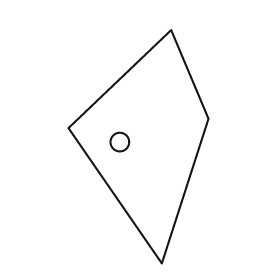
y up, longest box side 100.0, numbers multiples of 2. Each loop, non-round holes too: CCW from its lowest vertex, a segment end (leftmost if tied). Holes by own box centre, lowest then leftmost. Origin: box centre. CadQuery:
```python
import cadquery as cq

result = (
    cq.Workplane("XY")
    .moveTo(10.0, -50.0)
    .lineTo(30.0, 12.0)
    .lineTo(14.0, 50.0)
    .lineTo(-30.0, 8.0)
    .close()
    .moveTo(-8.0, 2.0)
    .circle(4.0)
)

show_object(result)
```